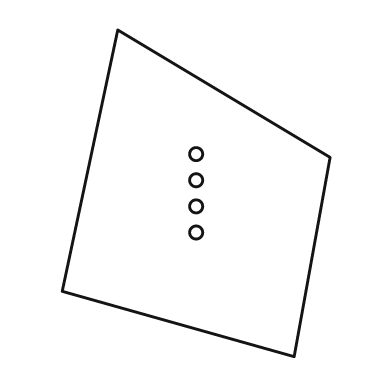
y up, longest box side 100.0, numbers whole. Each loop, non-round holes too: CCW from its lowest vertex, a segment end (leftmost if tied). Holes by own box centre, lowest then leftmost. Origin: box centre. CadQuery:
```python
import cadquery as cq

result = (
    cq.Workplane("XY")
    .moveTo(30.0, -50.0)
    .lineTo(41.0, 11.0)
    .lineTo(-24.0, 50.0)
    .lineTo(-41.0, -30.0)
    .close()
    .moveTo(0.0, -12.0)
    .circle(2.0)
    .moveTo(0.0, -4.0)
    .circle(2.0)
    .moveTo(0.0, 4.0)
    .circle(2.0)
    .moveTo(0.0, 12.0)
    .circle(2.0)
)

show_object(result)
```